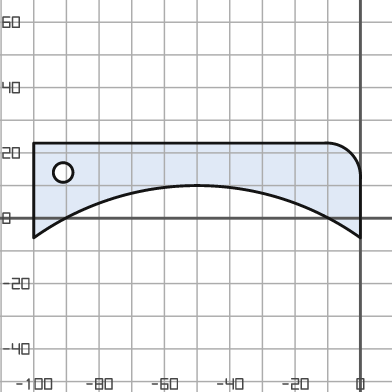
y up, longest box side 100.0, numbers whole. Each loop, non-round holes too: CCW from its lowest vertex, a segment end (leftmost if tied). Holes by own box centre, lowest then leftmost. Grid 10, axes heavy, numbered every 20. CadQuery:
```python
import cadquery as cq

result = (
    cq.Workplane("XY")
    .moveTo(-100.0, -6.0)
    .threePointArc((-50.0, 10.0), (0.0, -6.0))
    .lineTo(0.0, 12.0)
    .threePointArc((-3.0, 20.0), (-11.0, 23.0))
    .lineTo(-100.0, 23.0)
    .close()
    .moveTo(-91.0, 14.0)
    .circle(3.0)
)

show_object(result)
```